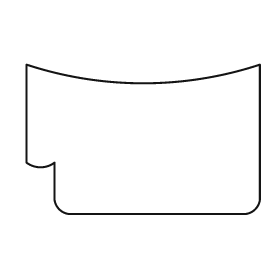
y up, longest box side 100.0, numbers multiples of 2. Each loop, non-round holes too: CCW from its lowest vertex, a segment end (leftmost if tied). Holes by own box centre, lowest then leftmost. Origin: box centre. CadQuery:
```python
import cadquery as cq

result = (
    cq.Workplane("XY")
    .moveTo(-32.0, -32.0)
    .lineTo(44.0, -32.0)
    .threePointArc((48.0, -30.0), (50.0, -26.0))
    .lineTo(50.0, 32.0)
    .threePointArc((0.0, 24.0), (-50.0, 32.0))
    .lineTo(-50.0, -10.0)
    .threePointArc((-44.0, -12.0), (-38.0, -10.0))
    .lineTo(-38.0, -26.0)
    .threePointArc((-36.0, -30.0), (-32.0, -32.0))
    .close()
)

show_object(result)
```